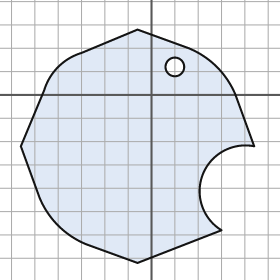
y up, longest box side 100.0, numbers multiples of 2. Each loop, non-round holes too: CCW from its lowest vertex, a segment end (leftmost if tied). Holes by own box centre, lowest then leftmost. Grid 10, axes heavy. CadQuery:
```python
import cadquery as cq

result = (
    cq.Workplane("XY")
    .moveTo(-6.0, -72.0)
    .lineTo(30.0, -58.0)
    .threePointArc((22.0, -34.0), (44.0, -22.0))
    .lineTo(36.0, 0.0)
    .threePointArc((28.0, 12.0), (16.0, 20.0))
    .lineTo(-6.0, 28.0)
    .lineTo(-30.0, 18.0)
    .threePointArc((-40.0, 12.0), (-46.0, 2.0))
    .lineTo(-56.0, -22.0)
    .lineTo(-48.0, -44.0)
    .threePointArc((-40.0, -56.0), (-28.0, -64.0))
    .close()
    .moveTo(10.0, 12.0)
    .circle(4.0)
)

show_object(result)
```